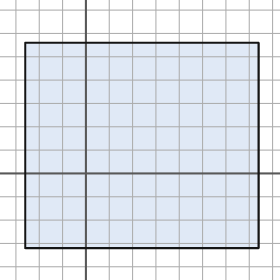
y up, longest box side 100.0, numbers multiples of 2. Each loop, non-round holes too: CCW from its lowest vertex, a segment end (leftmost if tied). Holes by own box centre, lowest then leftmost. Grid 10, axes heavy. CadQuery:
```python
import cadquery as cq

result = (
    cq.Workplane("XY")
    .moveTo(-26.0, -32.0)
    .lineTo(74.0, -32.0)
    .lineTo(74.0, 56.0)
    .lineTo(-26.0, 56.0)
    .close()
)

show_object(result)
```